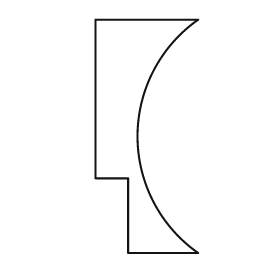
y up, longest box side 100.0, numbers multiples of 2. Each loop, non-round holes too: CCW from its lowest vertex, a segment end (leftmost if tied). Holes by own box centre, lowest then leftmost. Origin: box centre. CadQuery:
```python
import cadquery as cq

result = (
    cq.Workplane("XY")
    .moveTo(-8.0, -50.0)
    .lineTo(22.0, -50.0)
    .threePointArc((-4.0, 0.0), (22.0, 50.0))
    .lineTo(-22.0, 50.0)
    .lineTo(-22.0, -18.0)
    .lineTo(-8.0, -18.0)
    .close()
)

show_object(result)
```